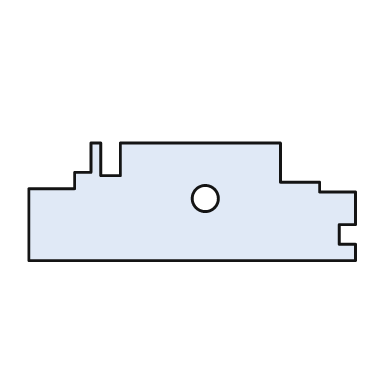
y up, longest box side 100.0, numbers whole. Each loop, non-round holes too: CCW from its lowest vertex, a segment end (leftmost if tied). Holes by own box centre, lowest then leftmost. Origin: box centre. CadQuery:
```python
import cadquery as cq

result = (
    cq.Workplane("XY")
    .moveTo(-50.0, -18.0)
    .lineTo(50.0, -18.0)
    .lineTo(50.0, -13.0)
    .lineTo(45.0, -13.0)
    .lineTo(45.0, -7.0)
    .lineTo(50.0, -7.0)
    .lineTo(50.0, 3.0)
    .lineTo(39.0, 3.0)
    .lineTo(39.0, 6.0)
    .lineTo(27.0, 6.0)
    .lineTo(27.0, 18.0)
    .lineTo(-22.0, 18.0)
    .lineTo(-22.0, 8.0)
    .lineTo(-28.0, 8.0)
    .lineTo(-28.0, 18.0)
    .lineTo(-31.0, 18.0)
    .lineTo(-31.0, 9.0)
    .lineTo(-36.0, 9.0)
    .lineTo(-36.0, 4.0)
    .lineTo(-50.0, 4.0)
    .close()
    .moveTo(4.0, 1.0)
    .circle(4.0)
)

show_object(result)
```